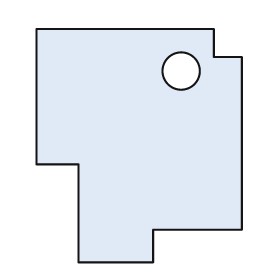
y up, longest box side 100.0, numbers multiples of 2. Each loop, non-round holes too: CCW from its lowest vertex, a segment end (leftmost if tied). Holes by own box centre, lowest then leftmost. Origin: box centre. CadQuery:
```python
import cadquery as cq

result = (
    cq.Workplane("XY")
    .moveTo(-26.0, -50.0)
    .lineTo(6.0, -50.0)
    .lineTo(6.0, -36.0)
    .lineTo(44.0, -36.0)
    .lineTo(44.0, 38.0)
    .lineTo(32.0, 38.0)
    .lineTo(32.0, 50.0)
    .lineTo(-44.0, 50.0)
    .lineTo(-44.0, -8.0)
    .lineTo(-26.0, -8.0)
    .close()
    .moveTo(18.0, 32.0)
    .circle(8.0)
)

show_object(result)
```